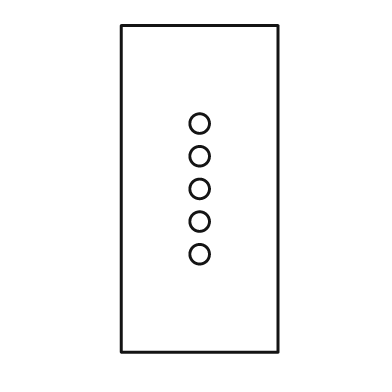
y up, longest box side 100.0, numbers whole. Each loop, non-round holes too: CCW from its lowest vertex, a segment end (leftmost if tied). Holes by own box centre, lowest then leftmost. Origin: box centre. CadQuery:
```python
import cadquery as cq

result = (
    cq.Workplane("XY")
    .moveTo(-24.0, -50.0)
    .lineTo(24.0, -50.0)
    .lineTo(24.0, 50.0)
    .lineTo(-24.0, 50.0)
    .close()
    .moveTo(0.0, -20.0)
    .circle(3.0)
    .moveTo(0.0, -10.0)
    .circle(3.0)
    .moveTo(0.0, 0.0)
    .circle(3.0)
    .moveTo(0.0, 10.0)
    .circle(3.0)
    .moveTo(0.0, 20.0)
    .circle(3.0)
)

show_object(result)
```